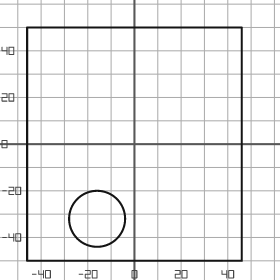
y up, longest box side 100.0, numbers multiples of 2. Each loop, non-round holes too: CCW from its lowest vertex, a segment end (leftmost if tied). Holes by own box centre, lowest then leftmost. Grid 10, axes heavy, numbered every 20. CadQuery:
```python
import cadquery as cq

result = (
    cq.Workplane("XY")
    .moveTo(-46.0, -50.0)
    .lineTo(46.0, -50.0)
    .lineTo(46.0, 50.0)
    .lineTo(-46.0, 50.0)
    .close()
    .moveTo(-16.0, -32.0)
    .circle(12.0)
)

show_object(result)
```